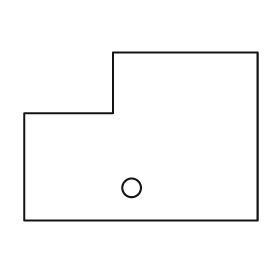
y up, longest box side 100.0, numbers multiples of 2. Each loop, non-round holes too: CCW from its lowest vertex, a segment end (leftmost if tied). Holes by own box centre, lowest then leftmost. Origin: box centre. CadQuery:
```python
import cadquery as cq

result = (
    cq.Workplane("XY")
    .moveTo(-50.0, -36.0)
    .lineTo(50.0, -36.0)
    .lineTo(50.0, 36.0)
    .lineTo(-12.0, 36.0)
    .lineTo(-12.0, 10.0)
    .lineTo(-50.0, 10.0)
    .close()
    .moveTo(-4.0, -22.0)
    .circle(4.0)
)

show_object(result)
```